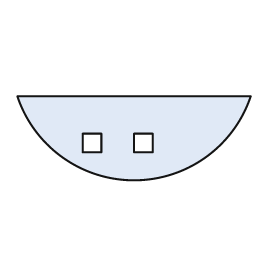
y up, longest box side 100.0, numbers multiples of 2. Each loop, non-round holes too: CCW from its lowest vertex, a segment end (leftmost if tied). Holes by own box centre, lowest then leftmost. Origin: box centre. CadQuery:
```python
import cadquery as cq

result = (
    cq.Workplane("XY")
    .moveTo(-50.0, 18.0)
    .threePointArc((0.0, -18.0), (50.0, 18.0))
    .close()
    .moveTo(-22.0, -6.0)
    .lineTo(-14.0, -6.0)
    .lineTo(-14.0, 2.0)
    .lineTo(-22.0, 2.0)
    .close()
    .moveTo(0.0, -6.0)
    .lineTo(8.0, -6.0)
    .lineTo(8.0, 2.0)
    .lineTo(0.0, 2.0)
    .close()
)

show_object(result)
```